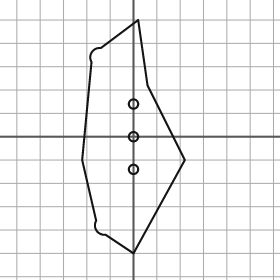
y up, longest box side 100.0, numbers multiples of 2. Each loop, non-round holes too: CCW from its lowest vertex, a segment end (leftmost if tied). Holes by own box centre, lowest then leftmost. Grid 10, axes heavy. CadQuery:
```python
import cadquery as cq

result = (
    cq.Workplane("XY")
    .moveTo(0.0, -50.0)
    .lineTo(22.0, -10.0)
    .lineTo(6.0, 22.0)
    .lineTo(2.0, 50.0)
    .lineTo(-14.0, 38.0)
    .threePointArc((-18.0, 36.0), (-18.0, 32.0))
    .lineTo(-22.0, -10.0)
    .lineTo(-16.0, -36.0)
    .threePointArc((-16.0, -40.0), (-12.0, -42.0))
    .close()
    .moveTo(0.0, -14.0)
    .circle(2.0)
    .moveTo(0.0, 0.0)
    .circle(2.0)
    .moveTo(0.0, 14.0)
    .circle(2.0)
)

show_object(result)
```